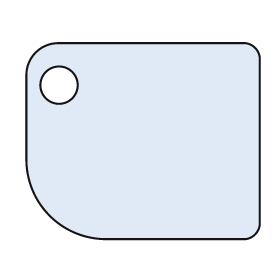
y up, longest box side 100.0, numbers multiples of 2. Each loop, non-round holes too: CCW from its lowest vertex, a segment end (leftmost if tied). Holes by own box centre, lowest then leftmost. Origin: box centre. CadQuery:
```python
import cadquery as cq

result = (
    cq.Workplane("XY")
    .moveTo(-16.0, -42.0)
    .lineTo(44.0, -42.0)
    .threePointArc((48.0, -40.0), (50.0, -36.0))
    .lineTo(50.0, 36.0)
    .threePointArc((48.0, 40.0), (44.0, 42.0))
    .lineTo(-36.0, 42.0)
    .threePointArc((-46.0, 38.0), (-50.0, 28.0))
    .lineTo(-50.0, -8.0)
    .threePointArc((-40.0, -32.0), (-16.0, -42.0))
    .close()
    .moveTo(-36.0, 24.0)
    .circle(8.0)
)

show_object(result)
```